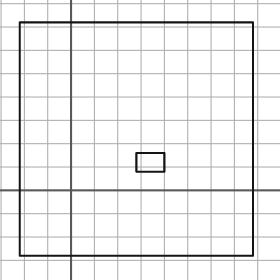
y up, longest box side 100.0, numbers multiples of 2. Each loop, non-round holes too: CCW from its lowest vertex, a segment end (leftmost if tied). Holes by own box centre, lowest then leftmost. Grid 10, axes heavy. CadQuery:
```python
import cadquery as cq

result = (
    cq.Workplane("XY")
    .moveTo(-22.0, -28.0)
    .lineTo(78.0, -28.0)
    .lineTo(78.0, 72.0)
    .lineTo(-22.0, 72.0)
    .close()
    .moveTo(28.0, 8.0)
    .lineTo(40.0, 8.0)
    .lineTo(40.0, 16.0)
    .lineTo(28.0, 16.0)
    .close()
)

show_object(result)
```